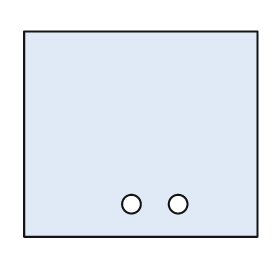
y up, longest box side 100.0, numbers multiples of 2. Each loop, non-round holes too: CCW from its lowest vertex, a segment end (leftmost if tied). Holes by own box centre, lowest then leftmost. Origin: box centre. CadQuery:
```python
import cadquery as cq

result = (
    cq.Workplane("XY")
    .moveTo(-50.0, -44.0)
    .lineTo(50.0, -44.0)
    .lineTo(50.0, 44.0)
    .lineTo(-50.0, 44.0)
    .close()
    .moveTo(-4.0, -30.0)
    .circle(4.0)
    .moveTo(16.0, -30.0)
    .circle(4.0)
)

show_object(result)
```